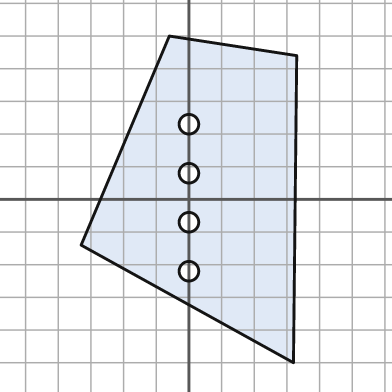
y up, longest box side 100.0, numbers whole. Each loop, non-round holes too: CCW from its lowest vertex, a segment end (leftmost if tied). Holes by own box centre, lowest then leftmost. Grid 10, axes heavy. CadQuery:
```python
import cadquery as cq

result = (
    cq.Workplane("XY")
    .moveTo(32.0, -50.0)
    .lineTo(33.0, 44.0)
    .lineTo(-6.0, 50.0)
    .lineTo(-33.0, -14.0)
    .close()
    .moveTo(0.0, -22.0)
    .circle(3.0)
    .moveTo(0.0, -7.0)
    .circle(3.0)
    .moveTo(0.0, 8.0)
    .circle(3.0)
    .moveTo(0.0, 23.0)
    .circle(3.0)
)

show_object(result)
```